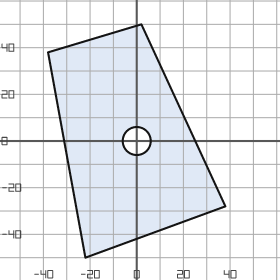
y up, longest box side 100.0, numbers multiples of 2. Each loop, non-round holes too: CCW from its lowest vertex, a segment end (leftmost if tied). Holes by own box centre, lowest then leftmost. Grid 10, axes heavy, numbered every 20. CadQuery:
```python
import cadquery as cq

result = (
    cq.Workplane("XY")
    .moveTo(-22.0, -50.0)
    .lineTo(38.0, -28.0)
    .lineTo(2.0, 50.0)
    .lineTo(-38.0, 38.0)
    .close()
    .moveTo(0.0, 0.0)
    .circle(6.0)
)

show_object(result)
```